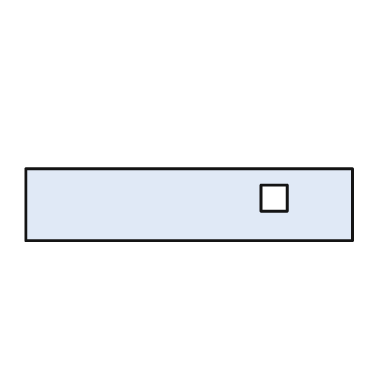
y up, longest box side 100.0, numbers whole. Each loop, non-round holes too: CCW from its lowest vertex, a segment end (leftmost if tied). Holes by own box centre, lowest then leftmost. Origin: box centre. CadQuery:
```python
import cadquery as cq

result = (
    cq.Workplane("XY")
    .moveTo(-50.0, -11.0)
    .lineTo(50.0, -11.0)
    .lineTo(50.0, 11.0)
    .lineTo(-50.0, 11.0)
    .close()
    .moveTo(22.0, -2.0)
    .lineTo(30.0, -2.0)
    .lineTo(30.0, 6.0)
    .lineTo(22.0, 6.0)
    .close()
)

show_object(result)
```